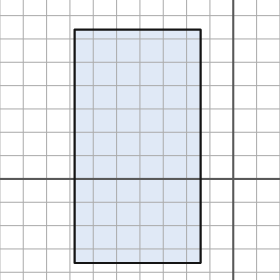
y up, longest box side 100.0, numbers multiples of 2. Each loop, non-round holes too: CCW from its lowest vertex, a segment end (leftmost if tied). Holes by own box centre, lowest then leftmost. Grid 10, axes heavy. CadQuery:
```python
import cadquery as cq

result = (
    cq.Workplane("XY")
    .moveTo(-68.0, -36.0)
    .lineTo(-14.0, -36.0)
    .lineTo(-14.0, 64.0)
    .lineTo(-68.0, 64.0)
    .close()
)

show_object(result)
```